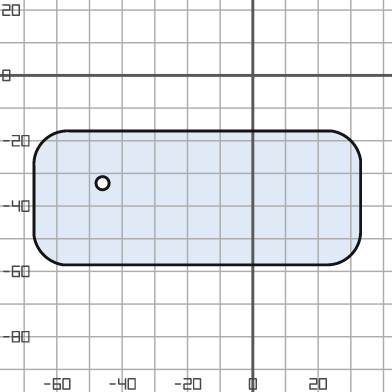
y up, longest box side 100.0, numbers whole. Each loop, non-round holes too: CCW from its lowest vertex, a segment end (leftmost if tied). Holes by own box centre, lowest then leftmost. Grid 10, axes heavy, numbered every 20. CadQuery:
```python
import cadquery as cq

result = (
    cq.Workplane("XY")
    .moveTo(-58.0, -58.0)
    .lineTo(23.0, -58.0)
    .threePointArc((30.0, -55.0), (33.0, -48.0))
    .lineTo(33.0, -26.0)
    .threePointArc((30.0, -20.0), (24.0, -17.0))
    .lineTo(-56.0, -17.0)
    .threePointArc((-64.0, -20.0), (-67.0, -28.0))
    .lineTo(-67.0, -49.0)
    .threePointArc((-64.0, -55.0), (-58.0, -58.0))
    .close()
    .moveTo(-46.0, -33.0)
    .circle(2.0)
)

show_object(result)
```